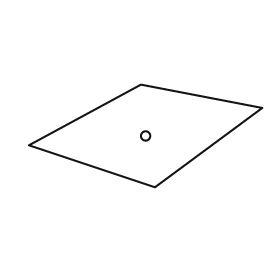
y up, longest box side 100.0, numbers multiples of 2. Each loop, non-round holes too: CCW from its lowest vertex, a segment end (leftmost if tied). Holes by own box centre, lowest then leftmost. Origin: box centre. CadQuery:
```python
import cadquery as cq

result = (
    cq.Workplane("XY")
    .moveTo(4.0, -22.0)
    .lineTo(50.0, 12.0)
    .lineTo(-2.0, 22.0)
    .lineTo(-50.0, -4.0)
    .close()
    .moveTo(0.0, 0.0)
    .circle(2.0)
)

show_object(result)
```